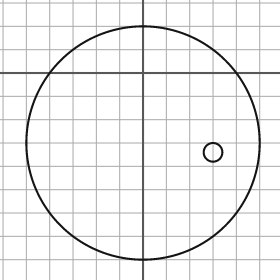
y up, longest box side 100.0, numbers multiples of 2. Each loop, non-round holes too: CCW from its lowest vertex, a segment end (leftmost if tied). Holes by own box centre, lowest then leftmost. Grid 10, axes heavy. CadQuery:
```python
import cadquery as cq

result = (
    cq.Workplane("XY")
    .moveTo(0.0, -30.0)
    .circle(50.0)
    .moveTo(30.0, -34.0)
    .circle(4.0)
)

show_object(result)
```